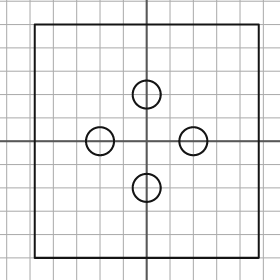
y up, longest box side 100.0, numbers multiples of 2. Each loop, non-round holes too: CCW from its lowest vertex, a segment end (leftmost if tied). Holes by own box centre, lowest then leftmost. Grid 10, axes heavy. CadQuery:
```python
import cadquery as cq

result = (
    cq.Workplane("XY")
    .moveTo(-48.0, -50.0)
    .lineTo(48.0, -50.0)
    .lineTo(48.0, 50.0)
    .lineTo(-48.0, 50.0)
    .close()
    .moveTo(0.0, -20.0)
    .circle(6.0)
    .moveTo(-20.0, 0.0)
    .circle(6.0)
    .moveTo(20.0, 0.0)
    .circle(6.0)
    .moveTo(0.0, 20.0)
    .circle(6.0)
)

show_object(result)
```